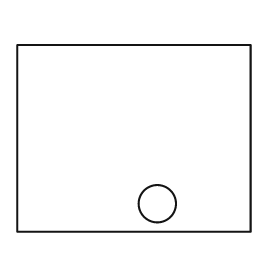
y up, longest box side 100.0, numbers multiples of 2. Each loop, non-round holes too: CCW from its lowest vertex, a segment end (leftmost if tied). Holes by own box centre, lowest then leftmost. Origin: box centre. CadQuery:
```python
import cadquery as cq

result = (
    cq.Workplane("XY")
    .moveTo(-50.0, -40.0)
    .lineTo(50.0, -40.0)
    .lineTo(50.0, 40.0)
    .lineTo(-50.0, 40.0)
    .close()
    .moveTo(10.0, -28.0)
    .circle(8.0)
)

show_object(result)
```